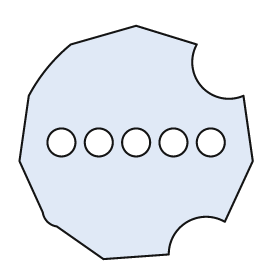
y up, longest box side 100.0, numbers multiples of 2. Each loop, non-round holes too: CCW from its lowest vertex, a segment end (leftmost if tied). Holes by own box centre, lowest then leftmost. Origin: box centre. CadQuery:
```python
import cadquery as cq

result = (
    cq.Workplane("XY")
    .moveTo(-14.0, -50.0)
    .lineTo(14.0, -48.0)
    .threePointArc((22.0, -34.0), (38.0, -34.0))
    .lineTo(50.0, -8.0)
    .lineTo(46.0, 20.0)
    .threePointArc((28.0, 24.0), (26.0, 42.0))
    .lineTo(0.0, 50.0)
    .lineTo(-28.0, 42.0)
    .threePointArc((-38.0, 32.0), (-46.0, 20.0))
    .lineTo(-50.0, -8.0)
    .lineTo(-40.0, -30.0)
    .threePointArc((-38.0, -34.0), (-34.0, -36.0))
    .close()
    .moveTo(-32.0, 0.0)
    .circle(6.0)
    .moveTo(-16.0, 0.0)
    .circle(6.0)
    .moveTo(0.0, 0.0)
    .circle(6.0)
    .moveTo(16.0, 0.0)
    .circle(6.0)
    .moveTo(32.0, 0.0)
    .circle(6.0)
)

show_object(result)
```